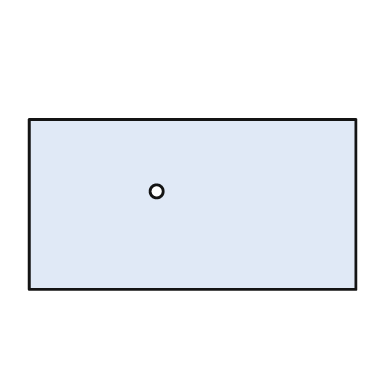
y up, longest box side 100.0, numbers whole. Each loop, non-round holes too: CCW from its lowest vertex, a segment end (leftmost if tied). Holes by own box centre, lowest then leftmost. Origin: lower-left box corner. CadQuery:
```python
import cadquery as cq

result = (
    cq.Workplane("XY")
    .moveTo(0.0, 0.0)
    .lineTo(100.0, 0.0)
    .lineTo(100.0, 52.0)
    .lineTo(0.0, 52.0)
    .close()
    .moveTo(39.0, 30.0)
    .circle(2.0)
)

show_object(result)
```